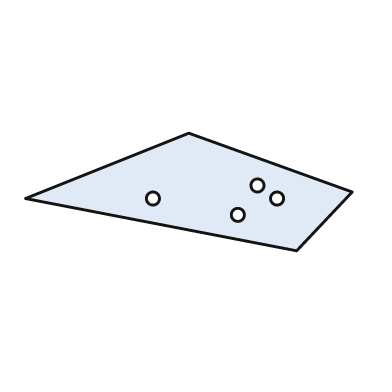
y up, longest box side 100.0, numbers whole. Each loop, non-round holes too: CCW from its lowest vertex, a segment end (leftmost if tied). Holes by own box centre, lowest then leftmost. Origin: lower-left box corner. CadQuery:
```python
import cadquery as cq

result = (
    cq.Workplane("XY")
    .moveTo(83.0, 0.0)
    .lineTo(100.0, 18.0)
    .lineTo(50.0, 36.0)
    .lineTo(0.0, 16.0)
    .close()
    .moveTo(65.0, 11.0)
    .circle(2.0)
    .moveTo(39.0, 16.0)
    .circle(2.0)
    .moveTo(77.0, 16.0)
    .circle(2.0)
    .moveTo(71.0, 20.0)
    .circle(2.0)
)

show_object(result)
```